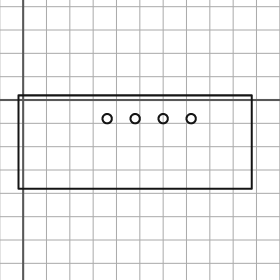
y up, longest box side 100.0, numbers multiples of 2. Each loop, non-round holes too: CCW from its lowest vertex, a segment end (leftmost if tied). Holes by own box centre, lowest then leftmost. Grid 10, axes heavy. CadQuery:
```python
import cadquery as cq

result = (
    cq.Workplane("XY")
    .moveTo(-2.0, -38.0)
    .lineTo(98.0, -38.0)
    .lineTo(98.0, 2.0)
    .lineTo(-2.0, 2.0)
    .close()
    .moveTo(36.0, -8.0)
    .circle(2.0)
    .moveTo(48.0, -8.0)
    .circle(2.0)
    .moveTo(60.0, -8.0)
    .circle(2.0)
    .moveTo(72.0, -8.0)
    .circle(2.0)
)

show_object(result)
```